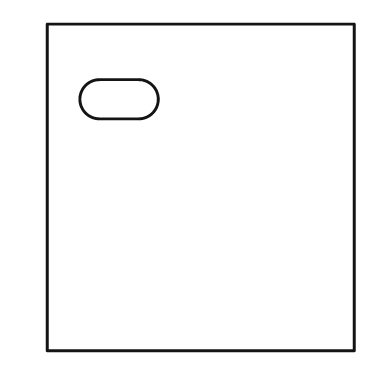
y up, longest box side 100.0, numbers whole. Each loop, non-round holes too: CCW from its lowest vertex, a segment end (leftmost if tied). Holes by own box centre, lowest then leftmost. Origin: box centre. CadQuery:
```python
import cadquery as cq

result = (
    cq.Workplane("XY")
    .moveTo(-47.0, -50.0)
    .lineTo(47.0, -50.0)
    .lineTo(47.0, 50.0)
    .lineTo(-47.0, 50.0)
    .close()
    .moveTo(-31.0, 21.0)
    .lineTo(-19.0, 21.0)
    .threePointArc((-13.0, 27.0), (-19.0, 33.0))
    .lineTo(-31.0, 33.0)
    .threePointArc((-37.0, 27.0), (-31.0, 21.0))
    .close()
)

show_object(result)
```